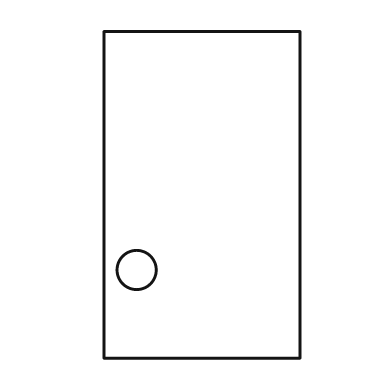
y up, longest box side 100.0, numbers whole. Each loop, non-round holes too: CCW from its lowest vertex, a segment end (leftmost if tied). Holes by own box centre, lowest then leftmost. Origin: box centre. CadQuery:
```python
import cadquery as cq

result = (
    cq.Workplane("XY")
    .moveTo(-30.0, -50.0)
    .lineTo(30.0, -50.0)
    .lineTo(30.0, 50.0)
    .lineTo(-30.0, 50.0)
    .close()
    .moveTo(-20.0, -23.0)
    .circle(6.0)
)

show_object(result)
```